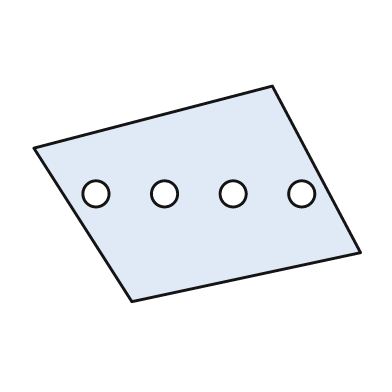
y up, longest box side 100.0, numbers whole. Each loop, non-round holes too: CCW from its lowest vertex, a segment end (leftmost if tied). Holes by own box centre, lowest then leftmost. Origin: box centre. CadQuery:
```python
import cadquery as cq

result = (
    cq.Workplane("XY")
    .moveTo(-20.0, -33.0)
    .lineTo(50.0, -18.0)
    .lineTo(23.0, 33.0)
    .lineTo(-50.0, 14.0)
    .close()
    .moveTo(-31.0, 0.0)
    .circle(4.0)
    .moveTo(-10.0, 0.0)
    .circle(4.0)
    .moveTo(11.0, 0.0)
    .circle(4.0)
    .moveTo(32.0, 0.0)
    .circle(4.0)
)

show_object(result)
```